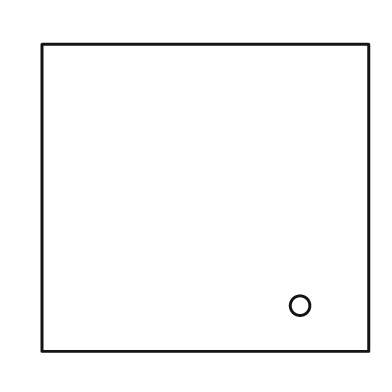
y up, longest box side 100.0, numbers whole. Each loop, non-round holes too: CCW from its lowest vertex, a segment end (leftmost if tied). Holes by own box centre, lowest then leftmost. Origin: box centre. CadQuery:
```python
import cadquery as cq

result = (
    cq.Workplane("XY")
    .moveTo(-50.0, -47.0)
    .lineTo(50.0, -47.0)
    .lineTo(50.0, 47.0)
    .lineTo(-50.0, 47.0)
    .close()
    .moveTo(29.0, -33.0)
    .circle(3.0)
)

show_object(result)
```